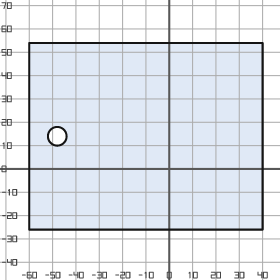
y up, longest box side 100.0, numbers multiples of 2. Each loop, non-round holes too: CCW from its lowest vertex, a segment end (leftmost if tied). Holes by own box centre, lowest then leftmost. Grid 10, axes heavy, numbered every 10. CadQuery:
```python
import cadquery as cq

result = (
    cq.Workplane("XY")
    .moveTo(-60.0, -26.0)
    .lineTo(40.0, -26.0)
    .lineTo(40.0, 54.0)
    .lineTo(-60.0, 54.0)
    .close()
    .moveTo(-48.0, 14.0)
    .circle(4.0)
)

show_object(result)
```